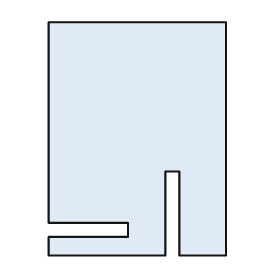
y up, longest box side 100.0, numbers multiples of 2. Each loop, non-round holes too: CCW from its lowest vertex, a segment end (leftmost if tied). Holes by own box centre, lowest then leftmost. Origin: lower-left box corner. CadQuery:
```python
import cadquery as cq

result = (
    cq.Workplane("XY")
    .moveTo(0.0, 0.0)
    .lineTo(50.0, 0.0)
    .lineTo(50.0, 36.0)
    .lineTo(56.0, 36.0)
    .lineTo(56.0, 0.0)
    .lineTo(76.0, 0.0)
    .lineTo(76.0, 100.0)
    .lineTo(0.0, 100.0)
    .lineTo(0.0, 14.0)
    .lineTo(34.0, 14.0)
    .lineTo(34.0, 8.0)
    .lineTo(0.0, 8.0)
    .close()
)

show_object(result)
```